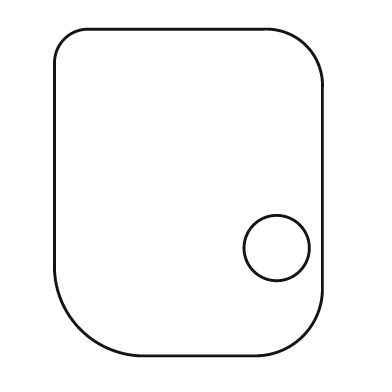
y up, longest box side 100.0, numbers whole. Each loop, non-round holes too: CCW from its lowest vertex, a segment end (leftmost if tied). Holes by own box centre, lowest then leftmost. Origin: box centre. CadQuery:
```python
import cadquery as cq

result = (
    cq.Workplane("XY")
    .moveTo(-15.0, -50.0)
    .lineTo(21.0, -50.0)
    .threePointArc((35.0, -44.0), (41.0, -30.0))
    .lineTo(41.0, 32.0)
    .threePointArc((36.0, 45.0), (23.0, 50.0))
    .lineTo(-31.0, 50.0)
    .threePointArc((-38.0, 47.0), (-41.0, 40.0))
    .lineTo(-41.0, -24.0)
    .threePointArc((-33.0, -42.0), (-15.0, -50.0))
    .close()
    .moveTo(27.0, -17.0)
    .circle(10.0)
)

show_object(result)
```